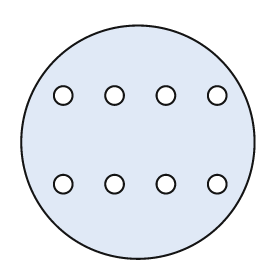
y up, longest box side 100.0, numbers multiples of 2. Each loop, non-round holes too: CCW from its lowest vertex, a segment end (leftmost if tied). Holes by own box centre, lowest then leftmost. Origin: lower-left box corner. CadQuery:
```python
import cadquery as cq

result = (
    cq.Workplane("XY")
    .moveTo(50.0, 50.0)
    .circle(50.0)
    .moveTo(18.0, 32.0)
    .circle(4.0)
    .moveTo(40.0, 32.0)
    .circle(4.0)
    .moveTo(62.0, 32.0)
    .circle(4.0)
    .moveTo(84.0, 32.0)
    .circle(4.0)
    .moveTo(18.0, 70.0)
    .circle(4.0)
    .moveTo(40.0, 70.0)
    .circle(4.0)
    .moveTo(62.0, 70.0)
    .circle(4.0)
    .moveTo(84.0, 70.0)
    .circle(4.0)
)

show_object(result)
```